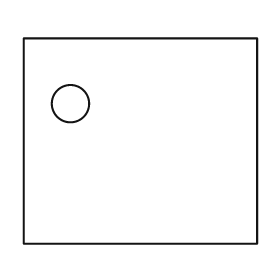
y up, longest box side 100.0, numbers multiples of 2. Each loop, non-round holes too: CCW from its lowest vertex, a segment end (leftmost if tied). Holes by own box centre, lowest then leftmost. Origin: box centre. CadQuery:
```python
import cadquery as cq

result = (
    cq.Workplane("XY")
    .moveTo(-50.0, -44.0)
    .lineTo(50.0, -44.0)
    .lineTo(50.0, 44.0)
    .lineTo(-50.0, 44.0)
    .close()
    .moveTo(-30.0, 16.0)
    .circle(8.0)
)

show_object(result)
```